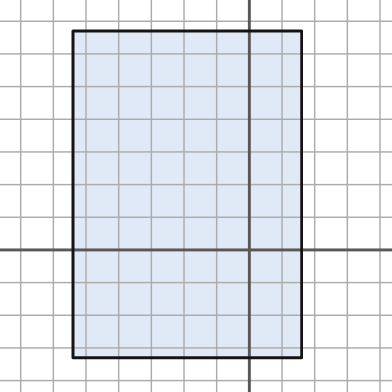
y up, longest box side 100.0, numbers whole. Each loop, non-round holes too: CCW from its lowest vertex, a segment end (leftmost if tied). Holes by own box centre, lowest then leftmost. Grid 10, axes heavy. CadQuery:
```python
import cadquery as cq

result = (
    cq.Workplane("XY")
    .moveTo(-54.0, -33.0)
    .lineTo(16.0, -33.0)
    .lineTo(16.0, 67.0)
    .lineTo(-54.0, 67.0)
    .close()
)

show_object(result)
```